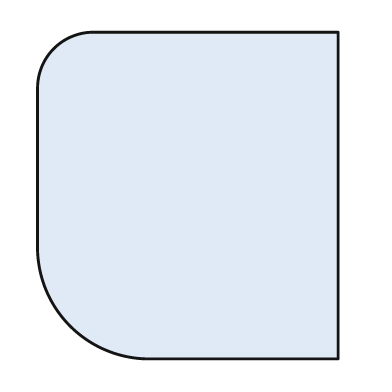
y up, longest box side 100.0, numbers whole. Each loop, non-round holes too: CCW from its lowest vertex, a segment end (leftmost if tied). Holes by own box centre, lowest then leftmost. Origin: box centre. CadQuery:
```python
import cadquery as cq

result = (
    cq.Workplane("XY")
    .moveTo(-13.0, -50.0)
    .lineTo(46.0, -50.0)
    .lineTo(46.0, 50.0)
    .lineTo(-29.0, 50.0)
    .threePointArc((-41.0, 45.0), (-46.0, 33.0))
    .lineTo(-46.0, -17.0)
    .threePointArc((-36.0, -40.0), (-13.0, -50.0))
    .close()
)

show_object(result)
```